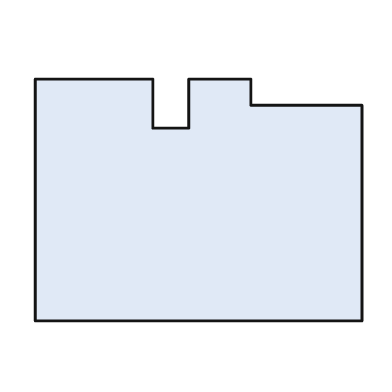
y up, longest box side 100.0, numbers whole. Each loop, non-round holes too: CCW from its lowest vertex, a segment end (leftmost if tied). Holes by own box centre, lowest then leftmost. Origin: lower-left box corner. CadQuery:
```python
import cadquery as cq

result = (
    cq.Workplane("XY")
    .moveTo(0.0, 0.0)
    .lineTo(100.0, 0.0)
    .lineTo(100.0, 66.0)
    .lineTo(66.0, 66.0)
    .lineTo(66.0, 74.0)
    .lineTo(47.0, 74.0)
    .lineTo(47.0, 59.0)
    .lineTo(36.0, 59.0)
    .lineTo(36.0, 74.0)
    .lineTo(0.0, 74.0)
    .close()
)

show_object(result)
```